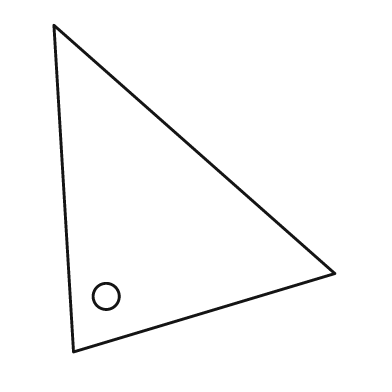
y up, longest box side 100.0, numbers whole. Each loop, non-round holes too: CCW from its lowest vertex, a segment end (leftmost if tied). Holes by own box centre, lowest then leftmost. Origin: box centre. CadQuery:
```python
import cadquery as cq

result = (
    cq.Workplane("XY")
    .moveTo(-37.0, -50.0)
    .lineTo(43.0, -26.0)
    .lineTo(-43.0, 50.0)
    .close()
    .moveTo(-27.0, -33.0)
    .circle(4.0)
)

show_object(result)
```